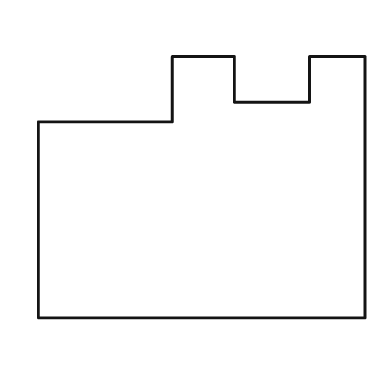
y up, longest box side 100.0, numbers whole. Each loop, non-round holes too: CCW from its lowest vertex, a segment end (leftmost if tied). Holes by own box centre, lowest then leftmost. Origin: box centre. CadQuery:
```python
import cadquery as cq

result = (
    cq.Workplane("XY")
    .moveTo(-50.0, -40.0)
    .lineTo(50.0, -40.0)
    .lineTo(50.0, 40.0)
    .lineTo(33.0, 40.0)
    .lineTo(33.0, 26.0)
    .lineTo(10.0, 26.0)
    .lineTo(10.0, 40.0)
    .lineTo(-9.0, 40.0)
    .lineTo(-9.0, 20.0)
    .lineTo(-50.0, 20.0)
    .close()
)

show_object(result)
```